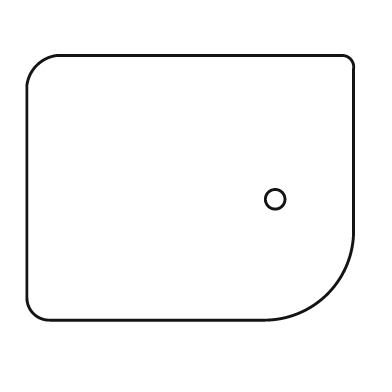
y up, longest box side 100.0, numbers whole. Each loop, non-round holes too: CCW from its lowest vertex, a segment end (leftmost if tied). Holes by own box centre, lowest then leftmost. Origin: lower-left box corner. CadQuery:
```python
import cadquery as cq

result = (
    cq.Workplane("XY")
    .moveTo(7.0, 0.0)
    .lineTo(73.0, 0.0)
    .threePointArc((92.0, 8.0), (100.0, 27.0))
    .lineTo(100.0, 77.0)
    .threePointArc((99.0, 80.0), (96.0, 81.0))
    .lineTo(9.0, 81.0)
    .threePointArc((3.0, 78.0), (0.0, 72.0))
    .lineTo(0.0, 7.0)
    .threePointArc((2.0, 2.0), (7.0, 0.0))
    .close()
    .moveTo(76.0, 37.0)
    .circle(3.0)
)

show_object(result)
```